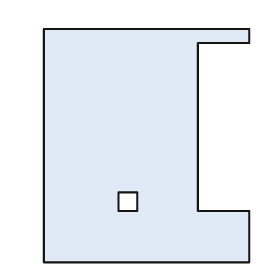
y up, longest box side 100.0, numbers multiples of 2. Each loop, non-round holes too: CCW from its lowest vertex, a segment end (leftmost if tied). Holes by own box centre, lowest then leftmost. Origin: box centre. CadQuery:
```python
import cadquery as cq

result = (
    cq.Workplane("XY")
    .moveTo(-44.0, -50.0)
    .lineTo(44.0, -50.0)
    .lineTo(44.0, -28.0)
    .lineTo(22.0, -28.0)
    .lineTo(22.0, 44.0)
    .lineTo(44.0, 44.0)
    .lineTo(44.0, 50.0)
    .lineTo(-44.0, 50.0)
    .close()
    .moveTo(-12.0, -28.0)
    .lineTo(-4.0, -28.0)
    .lineTo(-4.0, -20.0)
    .lineTo(-12.0, -20.0)
    .close()
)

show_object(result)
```